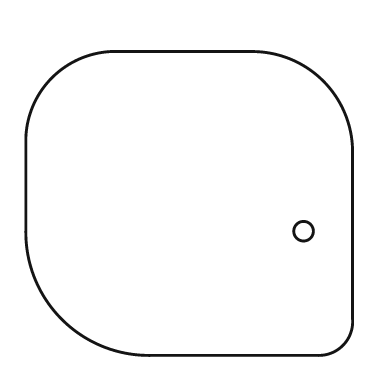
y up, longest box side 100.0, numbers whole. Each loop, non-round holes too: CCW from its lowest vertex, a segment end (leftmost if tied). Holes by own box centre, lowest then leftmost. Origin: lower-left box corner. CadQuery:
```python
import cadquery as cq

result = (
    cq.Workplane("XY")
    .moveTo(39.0, 0.0)
    .lineTo(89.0, 0.0)
    .threePointArc((97.0, 3.0), (100.0, 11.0))
    .lineTo(100.0, 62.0)
    .threePointArc((91.0, 84.0), (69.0, 93.0))
    .lineTo(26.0, 93.0)
    .threePointArc((8.0, 85.0), (0.0, 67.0))
    .lineTo(0.0, 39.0)
    .threePointArc((11.0, 11.0), (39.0, 0.0))
    .close()
    .moveTo(85.0, 38.0)
    .circle(3.0)
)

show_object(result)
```